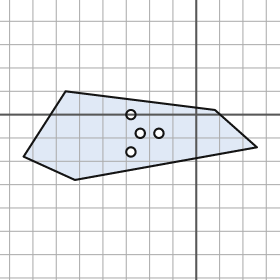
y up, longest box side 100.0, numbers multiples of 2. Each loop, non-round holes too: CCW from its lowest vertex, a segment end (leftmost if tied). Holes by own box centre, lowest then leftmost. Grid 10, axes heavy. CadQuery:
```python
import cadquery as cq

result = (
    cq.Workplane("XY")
    .moveTo(-52.0, -28.0)
    .lineTo(26.0, -14.0)
    .lineTo(8.0, 2.0)
    .lineTo(-56.0, 10.0)
    .lineTo(-74.0, -18.0)
    .close()
    .moveTo(-28.0, -16.0)
    .circle(2.0)
    .moveTo(-24.0, -8.0)
    .circle(2.0)
    .moveTo(-16.0, -8.0)
    .circle(2.0)
    .moveTo(-28.0, 0.0)
    .circle(2.0)
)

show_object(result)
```